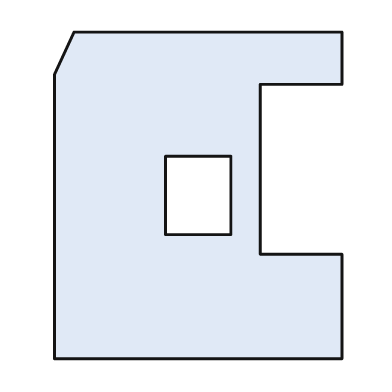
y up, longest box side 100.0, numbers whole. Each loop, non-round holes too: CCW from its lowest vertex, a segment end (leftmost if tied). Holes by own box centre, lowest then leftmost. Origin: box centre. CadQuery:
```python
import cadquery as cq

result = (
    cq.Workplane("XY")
    .moveTo(-44.0, -50.0)
    .lineTo(44.0, -50.0)
    .lineTo(44.0, -18.0)
    .lineTo(19.0, -18.0)
    .lineTo(19.0, 34.0)
    .lineTo(44.0, 34.0)
    .lineTo(44.0, 50.0)
    .lineTo(-38.0, 50.0)
    .lineTo(-44.0, 37.0)
    .close()
    .moveTo(-10.0, -12.0)
    .lineTo(10.0, -12.0)
    .lineTo(10.0, 12.0)
    .lineTo(-10.0, 12.0)
    .close()
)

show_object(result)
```